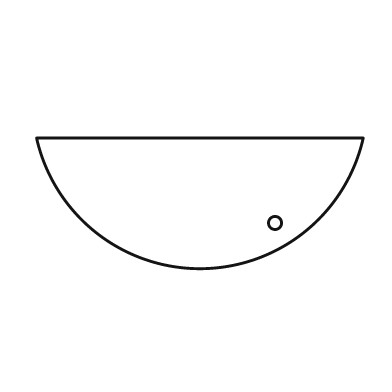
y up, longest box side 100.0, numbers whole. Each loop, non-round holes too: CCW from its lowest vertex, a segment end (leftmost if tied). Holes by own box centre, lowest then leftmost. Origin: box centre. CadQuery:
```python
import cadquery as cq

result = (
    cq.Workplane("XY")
    .moveTo(-50.0, 20.0)
    .threePointArc((0.0, -20.0), (50.0, 20.0))
    .close()
    .moveTo(23.0, -6.0)
    .circle(2.0)
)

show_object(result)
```